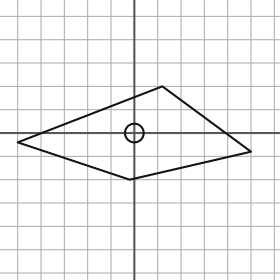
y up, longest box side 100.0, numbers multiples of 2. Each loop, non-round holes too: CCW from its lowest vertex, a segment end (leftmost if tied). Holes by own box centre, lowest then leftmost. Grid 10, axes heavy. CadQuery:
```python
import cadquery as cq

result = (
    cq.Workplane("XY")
    .moveTo(-2.0, -20.0)
    .lineTo(50.0, -8.0)
    .lineTo(12.0, 20.0)
    .lineTo(-50.0, -4.0)
    .close()
    .moveTo(0.0, 0.0)
    .circle(4.0)
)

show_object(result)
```